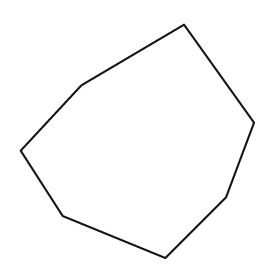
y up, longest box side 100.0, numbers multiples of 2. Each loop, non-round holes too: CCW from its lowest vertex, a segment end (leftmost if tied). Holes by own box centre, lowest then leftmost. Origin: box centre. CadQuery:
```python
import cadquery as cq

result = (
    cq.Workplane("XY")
    .moveTo(12.0, -50.0)
    .lineTo(38.0, -24.0)
    .lineTo(50.0, 8.0)
    .lineTo(20.0, 50.0)
    .lineTo(-24.0, 24.0)
    .lineTo(-50.0, -4.0)
    .lineTo(-32.0, -32.0)
    .close()
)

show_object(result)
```